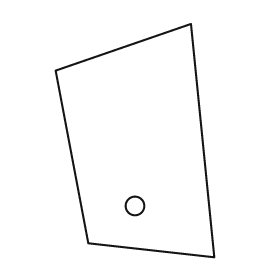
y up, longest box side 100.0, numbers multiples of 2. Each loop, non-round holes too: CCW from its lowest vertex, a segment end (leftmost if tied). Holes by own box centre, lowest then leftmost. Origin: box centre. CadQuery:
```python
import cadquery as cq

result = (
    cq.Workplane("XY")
    .moveTo(34.0, -50.0)
    .lineTo(24.0, 50.0)
    .lineTo(-34.0, 30.0)
    .lineTo(-20.0, -44.0)
    .close()
    .moveTo(0.0, -28.0)
    .circle(4.0)
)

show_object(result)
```